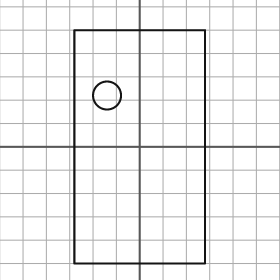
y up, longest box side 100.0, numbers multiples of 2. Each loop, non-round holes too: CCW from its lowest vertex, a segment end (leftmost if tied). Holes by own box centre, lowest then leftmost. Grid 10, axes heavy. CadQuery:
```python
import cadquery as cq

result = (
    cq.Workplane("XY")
    .moveTo(-28.0, -50.0)
    .lineTo(28.0, -50.0)
    .lineTo(28.0, 50.0)
    .lineTo(-28.0, 50.0)
    .close()
    .moveTo(-14.0, 22.0)
    .circle(6.0)
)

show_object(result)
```